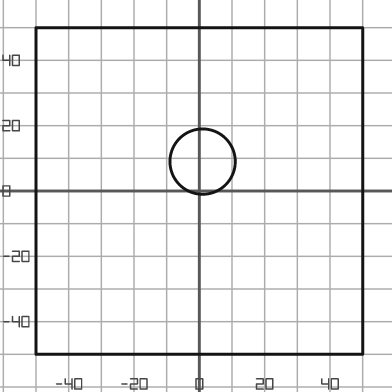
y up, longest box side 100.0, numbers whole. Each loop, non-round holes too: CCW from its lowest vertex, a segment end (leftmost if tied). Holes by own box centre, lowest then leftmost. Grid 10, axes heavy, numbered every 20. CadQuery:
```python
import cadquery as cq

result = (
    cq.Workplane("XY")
    .moveTo(-50.0, -50.0)
    .lineTo(50.0, -50.0)
    .lineTo(50.0, 50.0)
    .lineTo(-50.0, 50.0)
    .close()
    .moveTo(1.0, 9.0)
    .circle(10.0)
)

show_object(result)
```